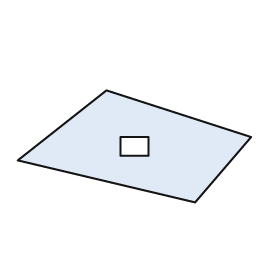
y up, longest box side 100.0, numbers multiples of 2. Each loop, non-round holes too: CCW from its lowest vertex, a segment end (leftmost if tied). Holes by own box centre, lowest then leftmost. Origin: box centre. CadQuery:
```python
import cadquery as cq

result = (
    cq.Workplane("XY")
    .moveTo(26.0, -24.0)
    .lineTo(50.0, 4.0)
    .lineTo(-12.0, 24.0)
    .lineTo(-50.0, -6.0)
    .close()
    .moveTo(-6.0, -4.0)
    .lineTo(6.0, -4.0)
    .lineTo(6.0, 4.0)
    .lineTo(-6.0, 4.0)
    .close()
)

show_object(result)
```